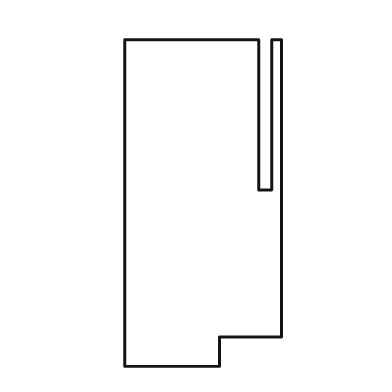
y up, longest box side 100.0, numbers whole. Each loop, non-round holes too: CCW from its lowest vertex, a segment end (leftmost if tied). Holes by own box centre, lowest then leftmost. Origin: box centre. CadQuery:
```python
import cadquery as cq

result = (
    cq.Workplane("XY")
    .moveTo(-24.0, -50.0)
    .lineTo(5.0, -50.0)
    .lineTo(5.0, -41.0)
    .lineTo(24.0, -41.0)
    .lineTo(24.0, 50.0)
    .lineTo(21.0, 50.0)
    .lineTo(21.0, 4.0)
    .lineTo(17.0, 4.0)
    .lineTo(17.0, 50.0)
    .lineTo(-24.0, 50.0)
    .close()
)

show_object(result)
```